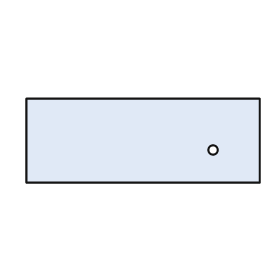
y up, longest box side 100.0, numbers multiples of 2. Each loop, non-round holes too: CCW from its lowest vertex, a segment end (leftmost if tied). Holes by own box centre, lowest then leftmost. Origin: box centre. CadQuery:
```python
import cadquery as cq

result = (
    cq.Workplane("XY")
    .moveTo(-50.0, -18.0)
    .lineTo(50.0, -18.0)
    .lineTo(50.0, 18.0)
    .lineTo(-50.0, 18.0)
    .close()
    .moveTo(30.0, -4.0)
    .circle(2.0)
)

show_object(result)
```